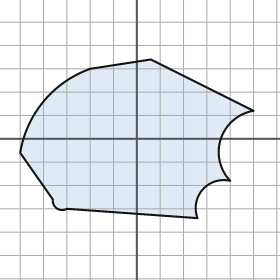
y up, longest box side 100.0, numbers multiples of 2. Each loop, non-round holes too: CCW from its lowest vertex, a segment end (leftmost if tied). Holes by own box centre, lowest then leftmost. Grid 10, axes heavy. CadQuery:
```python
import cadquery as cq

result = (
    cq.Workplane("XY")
    .moveTo(26.0, -34.0)
    .threePointArc((28.0, -22.0), (40.0, -18.0))
    .threePointArc((36.0, 0.0), (50.0, 12.0))
    .lineTo(6.0, 34.0)
    .lineTo(-20.0, 30.0)
    .threePointArc((-40.0, 16.0), (-50.0, -6.0))
    .lineTo(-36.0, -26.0)
    .threePointArc((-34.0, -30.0), (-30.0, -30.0))
    .close()
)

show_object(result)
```